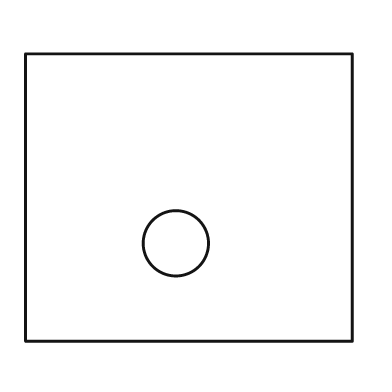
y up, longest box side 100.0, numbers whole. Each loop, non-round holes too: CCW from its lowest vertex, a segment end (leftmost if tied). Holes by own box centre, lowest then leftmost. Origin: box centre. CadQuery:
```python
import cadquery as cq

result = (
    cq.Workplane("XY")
    .moveTo(-50.0, -44.0)
    .lineTo(50.0, -44.0)
    .lineTo(50.0, 44.0)
    .lineTo(-50.0, 44.0)
    .close()
    .moveTo(-4.0, -14.0)
    .circle(10.0)
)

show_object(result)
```